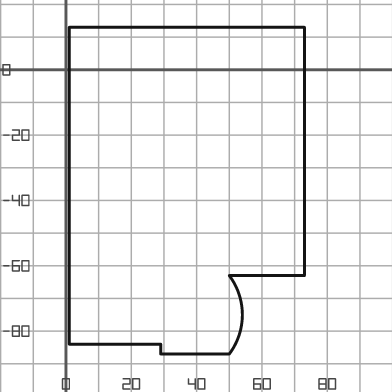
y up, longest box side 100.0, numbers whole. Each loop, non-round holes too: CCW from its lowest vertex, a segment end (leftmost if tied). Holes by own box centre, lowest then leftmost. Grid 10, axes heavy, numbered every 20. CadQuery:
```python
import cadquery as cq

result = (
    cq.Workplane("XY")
    .moveTo(29.0, -87.0)
    .lineTo(50.0, -87.0)
    .threePointArc((54.0, -75.0), (50.0, -63.0))
    .lineTo(73.0, -63.0)
    .lineTo(73.0, 13.0)
    .lineTo(1.0, 13.0)
    .lineTo(1.0, -84.0)
    .lineTo(29.0, -84.0)
    .close()
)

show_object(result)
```